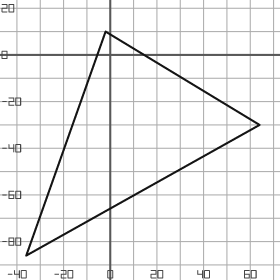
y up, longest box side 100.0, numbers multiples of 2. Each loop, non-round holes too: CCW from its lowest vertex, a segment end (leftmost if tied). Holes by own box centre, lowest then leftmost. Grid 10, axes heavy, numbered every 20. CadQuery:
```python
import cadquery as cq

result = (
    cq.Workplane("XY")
    .moveTo(-36.0, -86.0)
    .lineTo(64.0, -30.0)
    .lineTo(-2.0, 10.0)
    .close()
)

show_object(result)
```